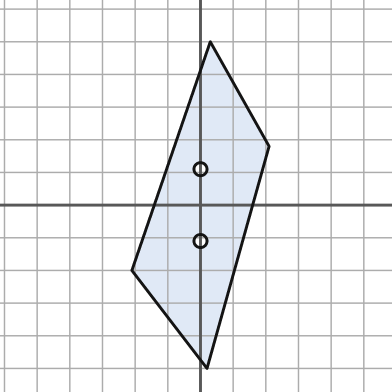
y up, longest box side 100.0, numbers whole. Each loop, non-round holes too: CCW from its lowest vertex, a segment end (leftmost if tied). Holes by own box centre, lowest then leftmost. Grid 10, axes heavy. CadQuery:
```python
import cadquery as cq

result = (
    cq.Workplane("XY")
    .moveTo(2.0, -50.0)
    .lineTo(21.0, 18.0)
    .lineTo(3.0, 50.0)
    .lineTo(-21.0, -20.0)
    .close()
    .moveTo(0.0, -11.0)
    .circle(2.0)
    .moveTo(0.0, 11.0)
    .circle(2.0)
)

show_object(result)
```